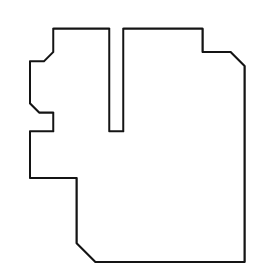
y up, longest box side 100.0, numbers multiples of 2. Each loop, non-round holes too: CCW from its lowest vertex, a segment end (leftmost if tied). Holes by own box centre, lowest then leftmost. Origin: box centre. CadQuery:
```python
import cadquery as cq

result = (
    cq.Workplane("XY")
    .moveTo(-18.0, -50.0)
    .lineTo(46.0, -50.0)
    .lineTo(46.0, 34.0)
    .lineTo(40.0, 40.0)
    .lineTo(28.0, 40.0)
    .lineTo(28.0, 50.0)
    .lineTo(-6.0, 50.0)
    .lineTo(-6.0, 6.0)
    .lineTo(-12.0, 6.0)
    .lineTo(-12.0, 50.0)
    .lineTo(-36.0, 50.0)
    .lineTo(-36.0, 40.0)
    .lineTo(-40.0, 36.0)
    .lineTo(-46.0, 36.0)
    .lineTo(-46.0, 18.0)
    .lineTo(-42.0, 14.0)
    .lineTo(-36.0, 14.0)
    .lineTo(-36.0, 6.0)
    .lineTo(-46.0, 6.0)
    .lineTo(-46.0, -14.0)
    .lineTo(-26.0, -14.0)
    .lineTo(-26.0, -42.0)
    .close()
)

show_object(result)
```